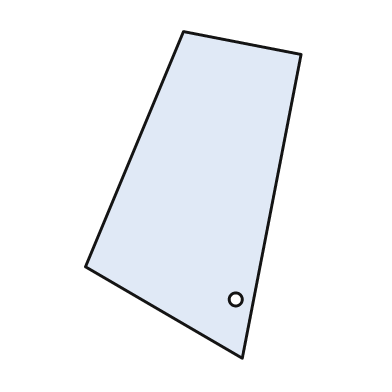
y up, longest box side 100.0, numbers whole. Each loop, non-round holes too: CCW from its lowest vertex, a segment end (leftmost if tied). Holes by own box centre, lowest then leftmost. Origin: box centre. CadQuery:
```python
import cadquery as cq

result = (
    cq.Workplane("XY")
    .moveTo(15.0, -50.0)
    .lineTo(33.0, 43.0)
    .lineTo(-3.0, 50.0)
    .lineTo(-33.0, -22.0)
    .close()
    .moveTo(13.0, -32.0)
    .circle(2.0)
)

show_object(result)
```